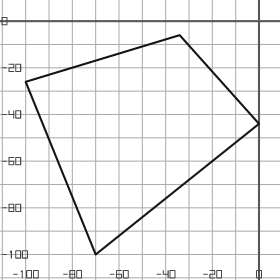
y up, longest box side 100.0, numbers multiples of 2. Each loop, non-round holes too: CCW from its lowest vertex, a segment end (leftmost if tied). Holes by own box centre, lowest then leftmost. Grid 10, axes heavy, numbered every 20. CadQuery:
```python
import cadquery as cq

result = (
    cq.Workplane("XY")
    .moveTo(-70.0, -100.0)
    .lineTo(0.0, -44.0)
    .lineTo(-34.0, -6.0)
    .lineTo(-100.0, -26.0)
    .close()
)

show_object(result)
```